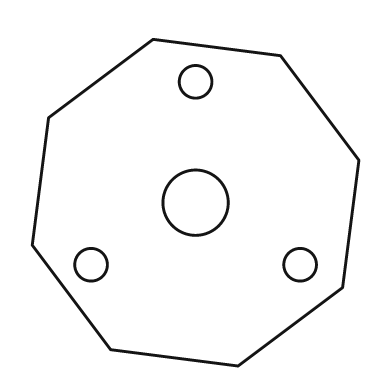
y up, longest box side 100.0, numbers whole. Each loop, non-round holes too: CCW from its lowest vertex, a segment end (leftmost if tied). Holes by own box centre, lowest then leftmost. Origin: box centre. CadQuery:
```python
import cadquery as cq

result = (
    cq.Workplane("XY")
    .moveTo(13.0, -50.0)
    .lineTo(45.0, -26.0)
    .lineTo(50.0, 13.0)
    .lineTo(26.0, 45.0)
    .lineTo(-13.0, 50.0)
    .lineTo(-45.0, 26.0)
    .lineTo(-50.0, -13.0)
    .lineTo(-26.0, -45.0)
    .close()
    .moveTo(-32.0, -19.0)
    .circle(5.0)
    .moveTo(32.0, -19.0)
    .circle(5.0)
    .moveTo(0.0, 0.0)
    .circle(10.0)
    .moveTo(0.0, 37.0)
    .circle(5.0)
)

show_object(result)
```